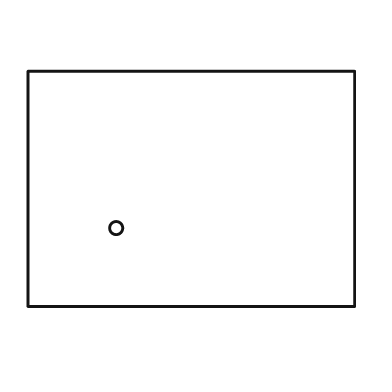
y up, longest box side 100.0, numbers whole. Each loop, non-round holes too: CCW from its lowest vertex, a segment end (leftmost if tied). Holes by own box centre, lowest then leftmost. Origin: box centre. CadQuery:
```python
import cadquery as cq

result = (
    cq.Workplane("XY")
    .moveTo(-50.0, -36.0)
    .lineTo(50.0, -36.0)
    .lineTo(50.0, 36.0)
    .lineTo(-50.0, 36.0)
    .close()
    .moveTo(-23.0, -12.0)
    .circle(2.0)
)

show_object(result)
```